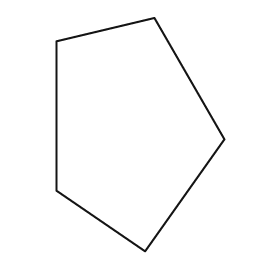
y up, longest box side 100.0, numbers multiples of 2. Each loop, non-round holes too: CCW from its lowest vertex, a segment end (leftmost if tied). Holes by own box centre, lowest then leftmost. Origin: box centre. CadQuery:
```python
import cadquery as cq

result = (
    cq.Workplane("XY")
    .moveTo(2.0, -50.0)
    .lineTo(36.0, -2.0)
    .lineTo(6.0, 50.0)
    .lineTo(-36.0, 40.0)
    .lineTo(-36.0, -24.0)
    .close()
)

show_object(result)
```